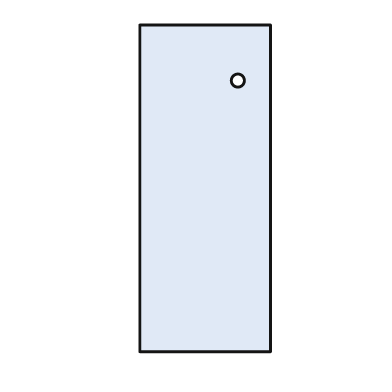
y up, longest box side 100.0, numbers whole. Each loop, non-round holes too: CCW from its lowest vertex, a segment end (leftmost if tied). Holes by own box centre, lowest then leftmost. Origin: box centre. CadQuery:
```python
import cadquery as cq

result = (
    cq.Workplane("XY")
    .moveTo(-20.0, -50.0)
    .lineTo(20.0, -50.0)
    .lineTo(20.0, 50.0)
    .lineTo(-20.0, 50.0)
    .close()
    .moveTo(10.0, 33.0)
    .circle(2.0)
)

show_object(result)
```